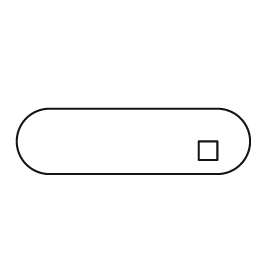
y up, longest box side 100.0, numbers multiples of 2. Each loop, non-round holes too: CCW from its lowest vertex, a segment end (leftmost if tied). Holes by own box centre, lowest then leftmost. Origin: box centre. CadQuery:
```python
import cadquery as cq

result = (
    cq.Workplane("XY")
    .moveTo(-36.0, -14.0)
    .lineTo(36.0, -14.0)
    .threePointArc((50.0, 0.0), (36.0, 14.0))
    .lineTo(-36.0, 14.0)
    .threePointArc((-50.0, 0.0), (-36.0, -14.0))
    .close()
    .moveTo(28.0, -8.0)
    .lineTo(36.0, -8.0)
    .lineTo(36.0, 0.0)
    .lineTo(28.0, 0.0)
    .close()
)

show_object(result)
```